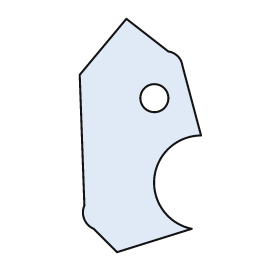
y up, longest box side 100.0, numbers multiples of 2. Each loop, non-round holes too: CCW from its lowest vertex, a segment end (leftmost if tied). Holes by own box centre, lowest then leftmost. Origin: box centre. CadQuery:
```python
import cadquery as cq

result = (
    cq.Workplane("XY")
    .moveTo(-10.0, -50.0)
    .lineTo(22.0, -40.0)
    .threePointArc((6.0, -18.0), (26.0, 0.0))
    .lineTo(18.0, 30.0)
    .threePointArc((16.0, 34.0), (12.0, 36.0))
    .lineTo(-6.0, 50.0)
    .lineTo(-26.0, 26.0)
    .lineTo(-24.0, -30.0)
    .threePointArc((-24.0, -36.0), (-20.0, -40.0))
    .close()
    .moveTo(6.0, 16.0)
    .circle(6.0)
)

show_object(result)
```